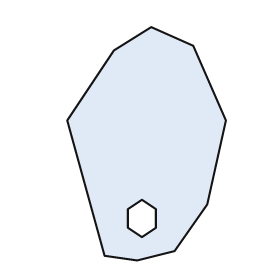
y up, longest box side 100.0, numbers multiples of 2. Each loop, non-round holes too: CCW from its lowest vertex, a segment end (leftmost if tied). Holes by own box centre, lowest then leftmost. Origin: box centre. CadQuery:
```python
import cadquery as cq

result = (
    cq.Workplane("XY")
    .moveTo(-4.0, -50.0)
    .lineTo(12.0, -46.0)
    .lineTo(26.0, -26.0)
    .lineTo(34.0, 10.0)
    .lineTo(20.0, 42.0)
    .lineTo(2.0, 50.0)
    .lineTo(-14.0, 40.0)
    .lineTo(-34.0, 10.0)
    .lineTo(-18.0, -48.0)
    .close()
    .moveTo(-2.0, -40.0)
    .lineTo(4.0, -36.0)
    .lineTo(4.0, -28.0)
    .lineTo(-2.0, -24.0)
    .lineTo(-8.0, -28.0)
    .lineTo(-8.0, -36.0)
    .close()
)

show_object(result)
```